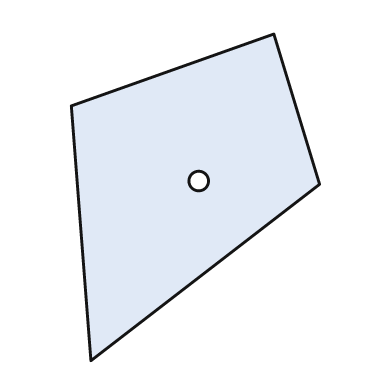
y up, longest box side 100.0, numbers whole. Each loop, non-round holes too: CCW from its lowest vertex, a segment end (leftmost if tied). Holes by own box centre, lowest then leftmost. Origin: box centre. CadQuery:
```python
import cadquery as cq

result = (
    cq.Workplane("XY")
    .moveTo(-32.0, -50.0)
    .lineTo(38.0, 4.0)
    .lineTo(24.0, 50.0)
    .lineTo(-38.0, 28.0)
    .close()
    .moveTo(1.0, 5.0)
    .circle(3.0)
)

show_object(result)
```